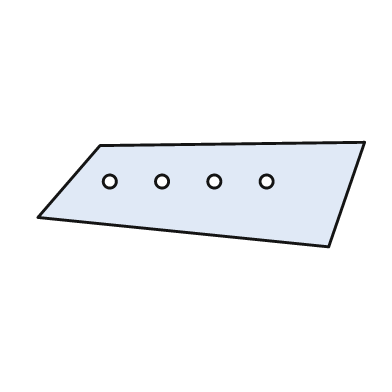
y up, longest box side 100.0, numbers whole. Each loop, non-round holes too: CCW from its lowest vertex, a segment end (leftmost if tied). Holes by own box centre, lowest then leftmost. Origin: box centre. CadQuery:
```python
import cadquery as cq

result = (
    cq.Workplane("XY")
    .moveTo(39.0, -16.0)
    .lineTo(50.0, 16.0)
    .lineTo(-31.0, 15.0)
    .lineTo(-50.0, -7.0)
    .close()
    .moveTo(-28.0, 4.0)
    .circle(2.0)
    .moveTo(-12.0, 4.0)
    .circle(2.0)
    .moveTo(4.0, 4.0)
    .circle(2.0)
    .moveTo(20.0, 4.0)
    .circle(2.0)
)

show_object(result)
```